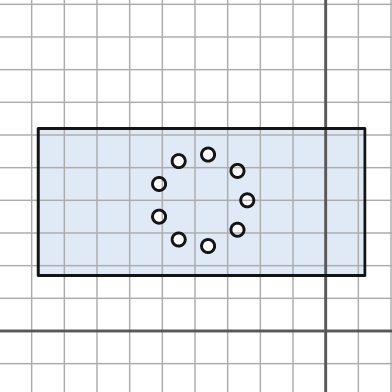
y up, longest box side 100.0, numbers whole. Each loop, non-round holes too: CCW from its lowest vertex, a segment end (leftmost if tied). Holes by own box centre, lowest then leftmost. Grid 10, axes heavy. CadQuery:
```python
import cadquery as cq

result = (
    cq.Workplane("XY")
    .moveTo(-88.0, 17.0)
    .lineTo(12.0, 17.0)
    .lineTo(12.0, 62.0)
    .lineTo(-88.0, 62.0)
    .close()
    .moveTo(-36.0, 26.0)
    .circle(2.0)
    .moveTo(-45.0, 28.0)
    .circle(2.0)
    .moveTo(-27.0, 31.0)
    .circle(2.0)
    .moveTo(-51.0, 35.0)
    .circle(2.0)
    .moveTo(-24.0, 40.0)
    .circle(2.0)
    .moveTo(-51.0, 45.0)
    .circle(2.0)
    .moveTo(-27.0, 49.0)
    .circle(2.0)
    .moveTo(-45.0, 52.0)
    .circle(2.0)
    .moveTo(-36.0, 54.0)
    .circle(2.0)
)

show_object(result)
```